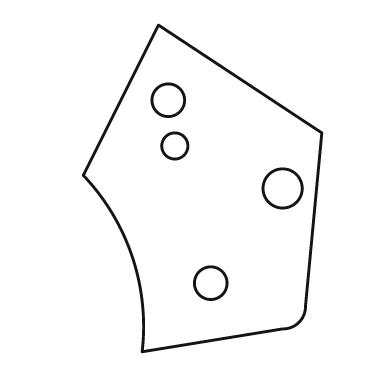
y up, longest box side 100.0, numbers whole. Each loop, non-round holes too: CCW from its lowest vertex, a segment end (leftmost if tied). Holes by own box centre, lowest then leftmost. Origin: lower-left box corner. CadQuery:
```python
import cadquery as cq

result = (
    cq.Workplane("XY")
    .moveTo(18.0, 0.0)
    .lineTo(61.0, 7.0)
    .threePointArc((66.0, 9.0), (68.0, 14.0))
    .lineTo(73.0, 67.0)
    .lineTo(23.0, 100.0)
    .lineTo(0.0, 54.0)
    .threePointArc((15.0, 29.0), (18.0, 0.0))
    .close()
    .moveTo(39.0, 21.0)
    .circle(5.0)
    .moveTo(61.0, 50.0)
    .circle(6.0)
    .moveTo(28.0, 63.0)
    .circle(4.0)
    .moveTo(26.0, 77.0)
    .circle(5.0)
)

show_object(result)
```